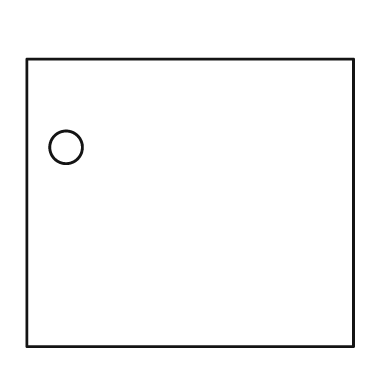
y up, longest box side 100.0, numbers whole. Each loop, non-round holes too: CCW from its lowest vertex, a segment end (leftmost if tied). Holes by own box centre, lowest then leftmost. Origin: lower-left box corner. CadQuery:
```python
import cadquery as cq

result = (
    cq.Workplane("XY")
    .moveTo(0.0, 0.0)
    .lineTo(100.0, 0.0)
    .lineTo(100.0, 88.0)
    .lineTo(0.0, 88.0)
    .close()
    .moveTo(12.0, 61.0)
    .circle(5.0)
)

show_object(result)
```